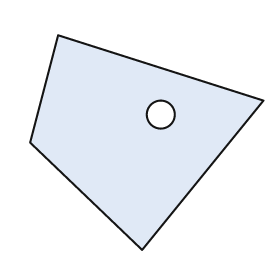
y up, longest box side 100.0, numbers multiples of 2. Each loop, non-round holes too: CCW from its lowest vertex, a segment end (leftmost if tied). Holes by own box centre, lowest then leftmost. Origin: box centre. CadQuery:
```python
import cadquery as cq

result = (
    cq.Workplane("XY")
    .moveTo(-2.0, -46.0)
    .lineTo(50.0, 18.0)
    .lineTo(-38.0, 46.0)
    .lineTo(-50.0, 0.0)
    .close()
    .moveTo(6.0, 12.0)
    .circle(6.0)
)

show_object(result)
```